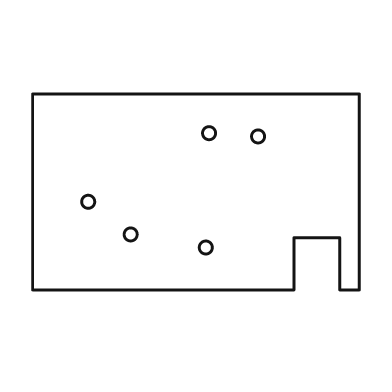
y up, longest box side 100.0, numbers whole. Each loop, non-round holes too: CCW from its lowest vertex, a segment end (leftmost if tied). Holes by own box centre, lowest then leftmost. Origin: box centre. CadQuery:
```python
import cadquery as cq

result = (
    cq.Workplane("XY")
    .moveTo(-50.0, -30.0)
    .lineTo(30.0, -30.0)
    .lineTo(30.0, -14.0)
    .lineTo(44.0, -14.0)
    .lineTo(44.0, -30.0)
    .lineTo(50.0, -30.0)
    .lineTo(50.0, 30.0)
    .lineTo(-50.0, 30.0)
    .close()
    .moveTo(3.0, -17.0)
    .circle(2.0)
    .moveTo(-20.0, -13.0)
    .circle(2.0)
    .moveTo(-33.0, -3.0)
    .circle(2.0)
    .moveTo(19.0, 17.0)
    .circle(2.0)
    .moveTo(4.0, 18.0)
    .circle(2.0)
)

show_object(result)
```